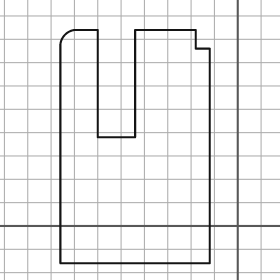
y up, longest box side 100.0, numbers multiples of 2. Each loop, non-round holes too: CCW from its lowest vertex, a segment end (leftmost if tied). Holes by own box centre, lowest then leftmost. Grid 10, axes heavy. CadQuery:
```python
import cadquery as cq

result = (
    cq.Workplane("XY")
    .moveTo(-76.0, -16.0)
    .lineTo(-12.0, -16.0)
    .lineTo(-12.0, 76.0)
    .lineTo(-18.0, 76.0)
    .lineTo(-18.0, 84.0)
    .lineTo(-44.0, 84.0)
    .lineTo(-44.0, 38.0)
    .lineTo(-60.0, 38.0)
    .lineTo(-60.0, 84.0)
    .lineTo(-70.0, 84.0)
    .threePointArc((-74.0, 82.0), (-76.0, 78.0))
    .close()
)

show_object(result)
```